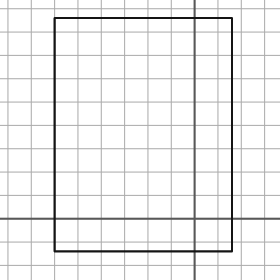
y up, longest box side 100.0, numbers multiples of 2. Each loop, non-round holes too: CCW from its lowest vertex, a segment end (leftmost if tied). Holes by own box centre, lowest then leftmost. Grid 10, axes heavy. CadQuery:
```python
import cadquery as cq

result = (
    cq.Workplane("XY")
    .moveTo(-60.0, -14.0)
    .lineTo(16.0, -14.0)
    .lineTo(16.0, 86.0)
    .lineTo(-60.0, 86.0)
    .close()
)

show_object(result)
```